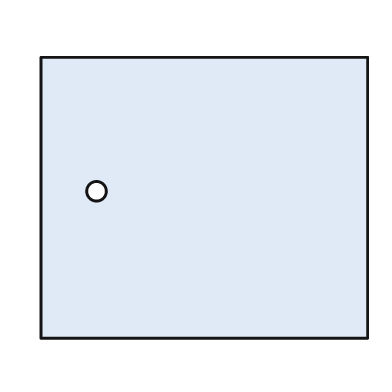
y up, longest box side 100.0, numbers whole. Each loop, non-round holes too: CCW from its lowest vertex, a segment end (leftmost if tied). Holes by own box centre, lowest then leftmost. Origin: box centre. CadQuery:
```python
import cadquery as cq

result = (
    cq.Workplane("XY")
    .moveTo(-50.0, -43.0)
    .lineTo(50.0, -43.0)
    .lineTo(50.0, 43.0)
    .lineTo(-50.0, 43.0)
    .close()
    .moveTo(-33.0, 2.0)
    .circle(3.0)
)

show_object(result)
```